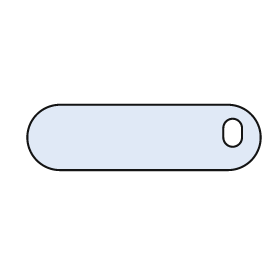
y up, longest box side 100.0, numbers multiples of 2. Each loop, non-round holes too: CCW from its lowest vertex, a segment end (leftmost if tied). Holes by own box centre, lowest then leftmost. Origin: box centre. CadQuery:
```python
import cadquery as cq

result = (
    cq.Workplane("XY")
    .moveTo(-36.0, -14.0)
    .lineTo(36.0, -14.0)
    .threePointArc((50.0, 0.0), (36.0, 14.0))
    .lineTo(-36.0, 14.0)
    .threePointArc((-50.0, 0.0), (-36.0, -14.0))
    .close()
    .moveTo(34.0, 0.0)
    .threePointArc((38.0, -4.0), (42.0, 0.0))
    .lineTo(42.0, 4.0)
    .threePointArc((38.0, 8.0), (34.0, 4.0))
    .close()
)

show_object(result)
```